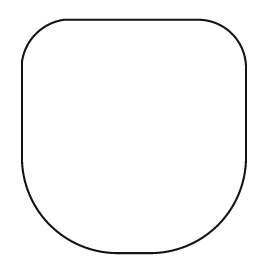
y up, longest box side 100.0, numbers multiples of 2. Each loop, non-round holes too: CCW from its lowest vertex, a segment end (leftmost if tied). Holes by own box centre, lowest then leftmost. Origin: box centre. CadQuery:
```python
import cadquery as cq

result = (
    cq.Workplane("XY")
    .moveTo(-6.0, -50.0)
    .lineTo(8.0, -50.0)
    .threePointArc((36.0, -38.0), (48.0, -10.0))
    .lineTo(48.0, 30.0)
    .threePointArc((42.0, 44.0), (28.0, 50.0))
    .lineTo(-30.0, 50.0)
    .threePointArc((-42.0, 44.0), (-48.0, 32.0))
    .lineTo(-48.0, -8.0)
    .threePointArc((-36.0, -38.0), (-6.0, -50.0))
    .close()
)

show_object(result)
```